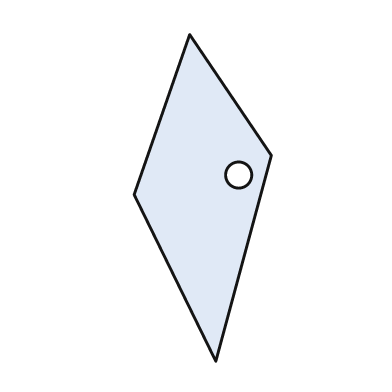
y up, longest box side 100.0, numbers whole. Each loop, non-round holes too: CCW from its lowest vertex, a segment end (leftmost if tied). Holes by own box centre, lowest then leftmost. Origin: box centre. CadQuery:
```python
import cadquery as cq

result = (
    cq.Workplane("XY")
    .moveTo(4.0, -50.0)
    .lineTo(21.0, 13.0)
    .lineTo(-4.0, 50.0)
    .lineTo(-21.0, 1.0)
    .close()
    .moveTo(11.0, 7.0)
    .circle(4.0)
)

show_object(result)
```